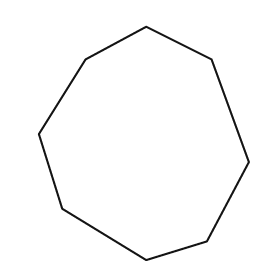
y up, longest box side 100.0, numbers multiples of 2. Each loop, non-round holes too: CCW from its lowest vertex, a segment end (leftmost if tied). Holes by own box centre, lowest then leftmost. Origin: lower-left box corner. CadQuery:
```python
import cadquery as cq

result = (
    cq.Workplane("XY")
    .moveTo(46.0, 0.0)
    .lineTo(72.0, 8.0)
    .lineTo(90.0, 42.0)
    .lineTo(74.0, 86.0)
    .lineTo(46.0, 100.0)
    .lineTo(20.0, 86.0)
    .lineTo(0.0, 54.0)
    .lineTo(10.0, 22.0)
    .close()
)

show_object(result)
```